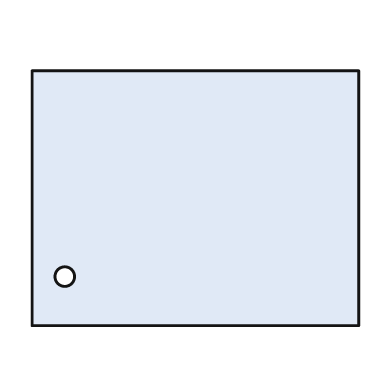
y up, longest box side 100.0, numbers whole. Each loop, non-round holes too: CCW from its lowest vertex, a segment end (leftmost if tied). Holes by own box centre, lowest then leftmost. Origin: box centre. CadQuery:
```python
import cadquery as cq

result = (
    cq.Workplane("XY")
    .moveTo(-50.0, -39.0)
    .lineTo(50.0, -39.0)
    .lineTo(50.0, 39.0)
    .lineTo(-50.0, 39.0)
    .close()
    .moveTo(-40.0, -24.0)
    .circle(3.0)
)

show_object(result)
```